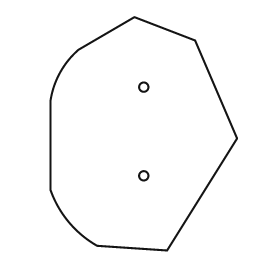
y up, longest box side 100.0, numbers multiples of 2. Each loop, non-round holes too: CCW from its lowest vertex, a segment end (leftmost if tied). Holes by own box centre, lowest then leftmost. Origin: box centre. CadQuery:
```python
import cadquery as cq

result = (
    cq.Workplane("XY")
    .moveTo(10.0, -50.0)
    .lineTo(40.0, -2.0)
    .lineTo(22.0, 40.0)
    .lineTo(-4.0, 50.0)
    .lineTo(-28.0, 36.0)
    .threePointArc((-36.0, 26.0), (-40.0, 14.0))
    .lineTo(-40.0, -24.0)
    .threePointArc((-32.0, -38.0), (-20.0, -48.0))
    .close()
    .moveTo(0.0, -18.0)
    .circle(2.0)
    .moveTo(0.0, 20.0)
    .circle(2.0)
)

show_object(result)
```